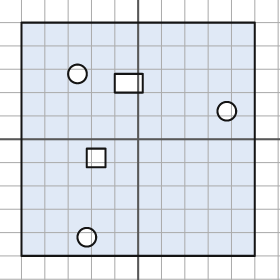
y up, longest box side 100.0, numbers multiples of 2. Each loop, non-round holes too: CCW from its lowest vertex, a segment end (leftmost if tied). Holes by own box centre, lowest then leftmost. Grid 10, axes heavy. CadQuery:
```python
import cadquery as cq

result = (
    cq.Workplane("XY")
    .moveTo(-50.0, -50.0)
    .lineTo(50.0, -50.0)
    .lineTo(50.0, 50.0)
    .lineTo(-50.0, 50.0)
    .close()
    .moveTo(-22.0, -42.0)
    .circle(4.0)
    .moveTo(-22.0, -12.0)
    .lineTo(-14.0, -12.0)
    .lineTo(-14.0, -4.0)
    .lineTo(-22.0, -4.0)
    .close()
    .moveTo(38.0, 12.0)
    .circle(4.0)
    .moveTo(-10.0, 20.0)
    .lineTo(2.0, 20.0)
    .lineTo(2.0, 28.0)
    .lineTo(-10.0, 28.0)
    .close()
    .moveTo(-26.0, 28.0)
    .circle(4.0)
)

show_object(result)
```